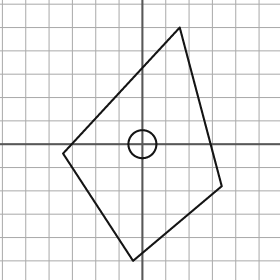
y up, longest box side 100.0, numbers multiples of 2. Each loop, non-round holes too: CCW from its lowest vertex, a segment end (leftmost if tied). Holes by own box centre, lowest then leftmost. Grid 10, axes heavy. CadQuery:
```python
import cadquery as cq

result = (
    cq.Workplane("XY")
    .moveTo(-4.0, -50.0)
    .lineTo(34.0, -18.0)
    .lineTo(16.0, 50.0)
    .lineTo(-34.0, -4.0)
    .close()
    .moveTo(0.0, 0.0)
    .circle(6.0)
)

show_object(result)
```